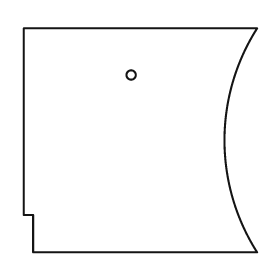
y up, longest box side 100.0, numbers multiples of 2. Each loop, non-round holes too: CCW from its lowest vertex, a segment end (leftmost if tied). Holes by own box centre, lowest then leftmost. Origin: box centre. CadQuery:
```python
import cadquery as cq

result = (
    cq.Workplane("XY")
    .moveTo(-46.0, -48.0)
    .lineTo(50.0, -48.0)
    .threePointArc((36.0, 0.0), (50.0, 48.0))
    .lineTo(-50.0, 48.0)
    .lineTo(-50.0, -32.0)
    .lineTo(-46.0, -32.0)
    .close()
    .moveTo(-4.0, 28.0)
    .circle(2.0)
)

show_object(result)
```